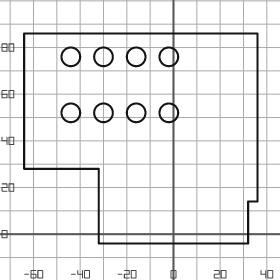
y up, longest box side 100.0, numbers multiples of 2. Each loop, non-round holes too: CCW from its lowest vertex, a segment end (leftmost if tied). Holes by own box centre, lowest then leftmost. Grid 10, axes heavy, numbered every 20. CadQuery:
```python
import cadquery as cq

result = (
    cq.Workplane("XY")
    .moveTo(-32.0, -4.0)
    .lineTo(32.0, -4.0)
    .lineTo(32.0, 14.0)
    .lineTo(36.0, 14.0)
    .lineTo(36.0, 86.0)
    .lineTo(-64.0, 86.0)
    .lineTo(-64.0, 28.0)
    .lineTo(-32.0, 28.0)
    .close()
    .moveTo(-44.0, 52.0)
    .circle(4.0)
    .moveTo(-30.0, 52.0)
    .circle(4.0)
    .moveTo(-16.0, 52.0)
    .circle(4.0)
    .moveTo(-2.0, 52.0)
    .circle(4.0)
    .moveTo(-44.0, 76.0)
    .circle(4.0)
    .moveTo(-30.0, 76.0)
    .circle(4.0)
    .moveTo(-16.0, 76.0)
    .circle(4.0)
    .moveTo(-2.0, 76.0)
    .circle(4.0)
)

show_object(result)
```